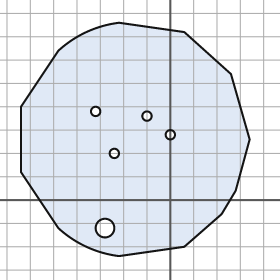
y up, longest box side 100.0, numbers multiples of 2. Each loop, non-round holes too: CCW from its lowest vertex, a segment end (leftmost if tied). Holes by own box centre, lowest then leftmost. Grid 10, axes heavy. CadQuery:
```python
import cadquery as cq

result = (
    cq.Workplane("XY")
    .moveTo(-22.0, -24.0)
    .lineTo(6.0, -20.0)
    .lineTo(22.0, -6.0)
    .lineTo(28.0, 4.0)
    .lineTo(34.0, 26.0)
    .lineTo(26.0, 54.0)
    .lineTo(6.0, 72.0)
    .lineTo(-22.0, 76.0)
    .threePointArc((-36.0, 72.0), (-48.0, 64.0))
    .lineTo(-64.0, 40.0)
    .lineTo(-64.0, 12.0)
    .lineTo(-48.0, -12.0)
    .threePointArc((-36.0, -20.0), (-22.0, -24.0))
    .close()
    .moveTo(-28.0, -12.0)
    .circle(4.0)
    .moveTo(-24.0, 20.0)
    .circle(2.0)
    .moveTo(0.0, 28.0)
    .circle(2.0)
    .moveTo(-10.0, 36.0)
    .circle(2.0)
    .moveTo(-32.0, 38.0)
    .circle(2.0)
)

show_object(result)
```